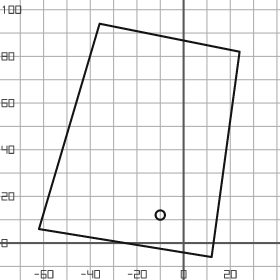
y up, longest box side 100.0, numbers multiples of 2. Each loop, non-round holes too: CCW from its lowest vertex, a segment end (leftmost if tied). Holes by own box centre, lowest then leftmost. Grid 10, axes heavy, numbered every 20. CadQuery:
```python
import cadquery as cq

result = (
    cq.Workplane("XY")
    .moveTo(12.0, -6.0)
    .lineTo(24.0, 82.0)
    .lineTo(-36.0, 94.0)
    .lineTo(-62.0, 6.0)
    .close()
    .moveTo(-10.0, 12.0)
    .circle(2.0)
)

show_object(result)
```